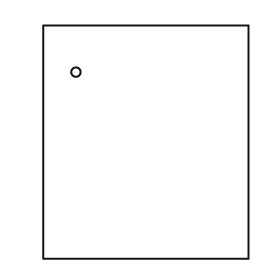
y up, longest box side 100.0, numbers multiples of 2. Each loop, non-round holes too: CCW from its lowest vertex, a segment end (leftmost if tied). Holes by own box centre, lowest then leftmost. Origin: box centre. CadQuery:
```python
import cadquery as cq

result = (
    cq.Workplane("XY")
    .moveTo(-44.0, -50.0)
    .lineTo(44.0, -50.0)
    .lineTo(44.0, 50.0)
    .lineTo(-44.0, 50.0)
    .close()
    .moveTo(-30.0, 30.0)
    .circle(2.0)
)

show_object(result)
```